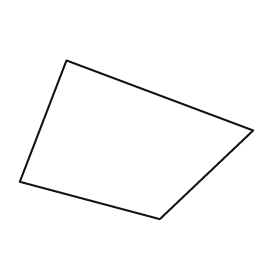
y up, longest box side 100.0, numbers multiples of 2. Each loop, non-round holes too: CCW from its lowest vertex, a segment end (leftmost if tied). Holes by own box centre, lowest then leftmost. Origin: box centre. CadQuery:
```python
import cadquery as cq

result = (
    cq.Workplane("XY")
    .moveTo(10.0, -34.0)
    .lineTo(50.0, 4.0)
    .lineTo(-30.0, 34.0)
    .lineTo(-50.0, -18.0)
    .close()
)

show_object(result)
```